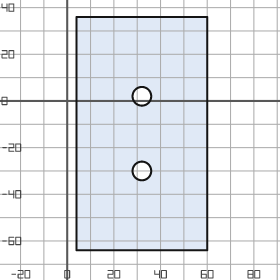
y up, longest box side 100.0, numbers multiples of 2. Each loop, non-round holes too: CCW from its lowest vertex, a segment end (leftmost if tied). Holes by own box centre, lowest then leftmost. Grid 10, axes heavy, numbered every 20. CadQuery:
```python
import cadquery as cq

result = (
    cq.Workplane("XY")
    .moveTo(4.0, -64.0)
    .lineTo(60.0, -64.0)
    .lineTo(60.0, 36.0)
    .lineTo(4.0, 36.0)
    .close()
    .moveTo(32.0, -30.0)
    .circle(4.0)
    .moveTo(32.0, 2.0)
    .circle(4.0)
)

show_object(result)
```